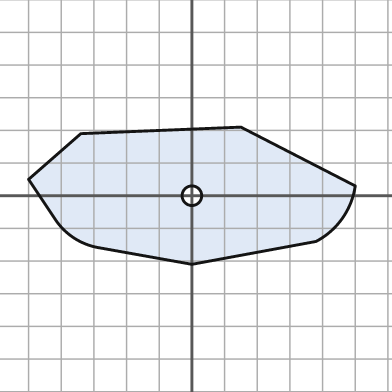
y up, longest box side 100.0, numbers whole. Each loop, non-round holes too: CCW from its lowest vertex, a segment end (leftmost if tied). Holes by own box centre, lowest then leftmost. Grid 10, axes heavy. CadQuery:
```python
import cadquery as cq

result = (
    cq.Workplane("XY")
    .moveTo(0.0, -21.0)
    .lineTo(38.0, -14.0)
    .threePointArc((46.0, -7.0), (50.0, 3.0))
    .lineTo(15.0, 21.0)
    .lineTo(-34.0, 19.0)
    .lineTo(-50.0, 5.0)
    .lineTo(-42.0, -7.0)
    .threePointArc((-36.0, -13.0), (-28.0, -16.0))
    .close()
    .moveTo(0.0, 0.0)
    .circle(3.0)
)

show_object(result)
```